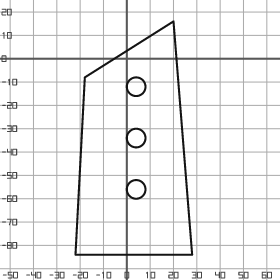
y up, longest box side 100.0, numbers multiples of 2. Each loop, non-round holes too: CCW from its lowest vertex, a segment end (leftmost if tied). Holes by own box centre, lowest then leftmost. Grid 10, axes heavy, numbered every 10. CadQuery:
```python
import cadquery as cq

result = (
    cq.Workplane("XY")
    .moveTo(-22.0, -84.0)
    .lineTo(28.0, -84.0)
    .lineTo(20.0, 16.0)
    .lineTo(-18.0, -8.0)
    .close()
    .moveTo(4.0, -56.0)
    .circle(4.0)
    .moveTo(4.0, -34.0)
    .circle(4.0)
    .moveTo(4.0, -12.0)
    .circle(4.0)
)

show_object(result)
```